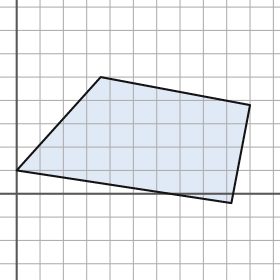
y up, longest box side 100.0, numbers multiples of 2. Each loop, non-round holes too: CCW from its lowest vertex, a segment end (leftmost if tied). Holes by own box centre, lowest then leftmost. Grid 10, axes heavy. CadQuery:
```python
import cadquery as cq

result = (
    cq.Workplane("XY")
    .moveTo(92.0, -4.0)
    .lineTo(100.0, 38.0)
    .lineTo(36.0, 50.0)
    .lineTo(0.0, 10.0)
    .close()
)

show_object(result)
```